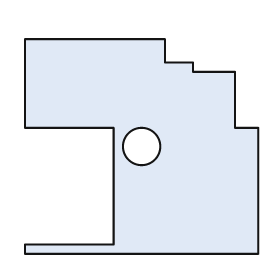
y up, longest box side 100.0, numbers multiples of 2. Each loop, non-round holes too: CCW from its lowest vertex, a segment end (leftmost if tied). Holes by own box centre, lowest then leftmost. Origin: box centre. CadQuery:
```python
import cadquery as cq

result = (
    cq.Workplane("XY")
    .moveTo(-50.0, -46.0)
    .lineTo(50.0, -46.0)
    .lineTo(50.0, 8.0)
    .lineTo(40.0, 8.0)
    .lineTo(40.0, 32.0)
    .lineTo(22.0, 32.0)
    .lineTo(22.0, 36.0)
    .lineTo(10.0, 36.0)
    .lineTo(10.0, 46.0)
    .lineTo(-50.0, 46.0)
    .lineTo(-50.0, 8.0)
    .lineTo(-12.0, 8.0)
    .lineTo(-12.0, -42.0)
    .lineTo(-50.0, -42.0)
    .close()
    .moveTo(0.0, 0.0)
    .circle(8.0)
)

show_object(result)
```